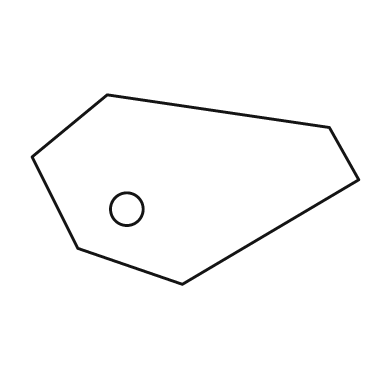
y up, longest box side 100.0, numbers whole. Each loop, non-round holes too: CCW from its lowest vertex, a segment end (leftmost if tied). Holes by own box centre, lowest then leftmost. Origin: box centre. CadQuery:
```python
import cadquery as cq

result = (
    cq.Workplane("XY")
    .moveTo(-4.0, -29.0)
    .lineTo(50.0, 3.0)
    .lineTo(41.0, 19.0)
    .lineTo(-27.0, 29.0)
    .lineTo(-50.0, 10.0)
    .lineTo(-36.0, -18.0)
    .close()
    .moveTo(-21.0, -6.0)
    .circle(5.0)
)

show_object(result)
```